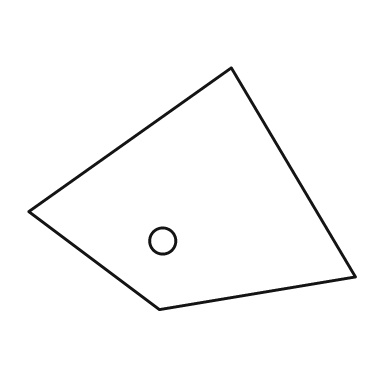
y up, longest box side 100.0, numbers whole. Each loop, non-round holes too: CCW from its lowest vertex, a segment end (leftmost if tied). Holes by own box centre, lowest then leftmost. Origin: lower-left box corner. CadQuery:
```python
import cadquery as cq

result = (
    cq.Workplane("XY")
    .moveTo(40.0, 0.0)
    .lineTo(100.0, 10.0)
    .lineTo(62.0, 74.0)
    .lineTo(0.0, 30.0)
    .close()
    .moveTo(41.0, 21.0)
    .circle(4.0)
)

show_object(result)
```